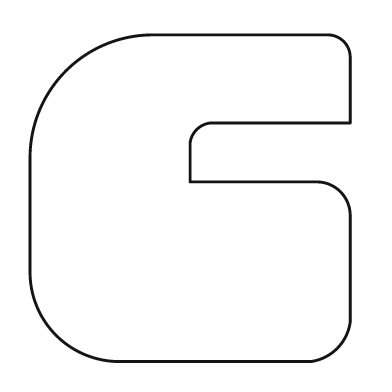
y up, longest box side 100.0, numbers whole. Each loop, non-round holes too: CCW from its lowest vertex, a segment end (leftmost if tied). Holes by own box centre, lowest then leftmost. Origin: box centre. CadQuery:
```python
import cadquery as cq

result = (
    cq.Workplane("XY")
    .moveTo(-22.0, -50.0)
    .lineTo(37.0, -50.0)
    .threePointArc((45.0, -46.0), (49.0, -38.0))
    .lineTo(49.0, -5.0)
    .threePointArc((46.0, 2.0), (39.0, 5.0))
    .lineTo(0.0, 5.0)
    .lineTo(0.0, 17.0)
    .threePointArc((2.0, 21.0), (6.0, 23.0))
    .lineTo(49.0, 23.0)
    .lineTo(49.0, 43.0)
    .threePointArc((47.0, 48.0), (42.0, 50.0))
    .lineTo(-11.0, 50.0)
    .threePointArc((-38.0, 39.0), (-49.0, 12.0))
    .lineTo(-49.0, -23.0)
    .threePointArc((-41.0, -42.0), (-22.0, -50.0))
    .close()
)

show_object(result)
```